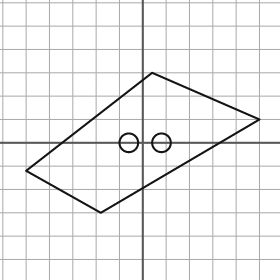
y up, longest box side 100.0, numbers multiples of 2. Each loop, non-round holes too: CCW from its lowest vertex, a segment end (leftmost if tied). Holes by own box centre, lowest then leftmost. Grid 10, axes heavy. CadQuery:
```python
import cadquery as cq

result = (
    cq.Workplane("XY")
    .moveTo(-18.0, -30.0)
    .lineTo(50.0, 10.0)
    .lineTo(4.0, 30.0)
    .lineTo(-50.0, -12.0)
    .close()
    .moveTo(-6.0, 0.0)
    .circle(4.0)
    .moveTo(8.0, 0.0)
    .circle(4.0)
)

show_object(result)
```